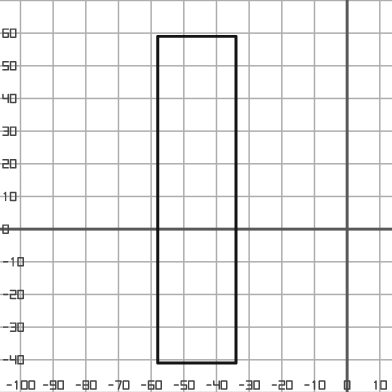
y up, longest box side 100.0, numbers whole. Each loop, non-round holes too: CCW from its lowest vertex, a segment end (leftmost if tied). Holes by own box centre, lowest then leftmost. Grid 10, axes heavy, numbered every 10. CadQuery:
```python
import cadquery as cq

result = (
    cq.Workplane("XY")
    .moveTo(-58.0, -41.0)
    .lineTo(-34.0, -41.0)
    .lineTo(-34.0, 59.0)
    .lineTo(-58.0, 59.0)
    .close()
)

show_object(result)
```